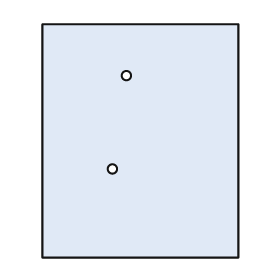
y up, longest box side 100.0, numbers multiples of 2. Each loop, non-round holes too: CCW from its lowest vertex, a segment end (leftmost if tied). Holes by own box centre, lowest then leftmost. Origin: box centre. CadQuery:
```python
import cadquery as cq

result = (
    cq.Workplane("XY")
    .moveTo(-42.0, -50.0)
    .lineTo(42.0, -50.0)
    .lineTo(42.0, 50.0)
    .lineTo(-42.0, 50.0)
    .close()
    .moveTo(-12.0, -12.0)
    .circle(2.0)
    .moveTo(-6.0, 28.0)
    .circle(2.0)
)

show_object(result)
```